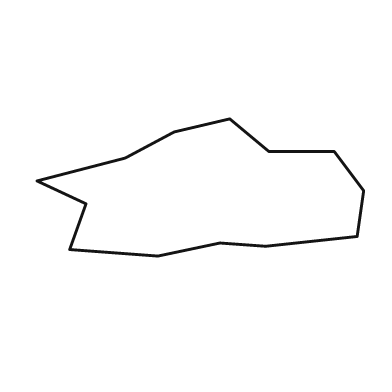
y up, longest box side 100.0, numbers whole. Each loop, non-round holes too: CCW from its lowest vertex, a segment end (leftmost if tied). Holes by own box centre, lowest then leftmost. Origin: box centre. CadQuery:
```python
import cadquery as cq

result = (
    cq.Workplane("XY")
    .moveTo(-13.0, -21.0)
    .lineTo(6.0, -17.0)
    .lineTo(20.0, -18.0)
    .lineTo(48.0, -15.0)
    .lineTo(50.0, -1.0)
    .lineTo(41.0, 11.0)
    .lineTo(21.0, 11.0)
    .lineTo(9.0, 21.0)
    .lineTo(-8.0, 17.0)
    .lineTo(-23.0, 9.0)
    .lineTo(-50.0, 2.0)
    .lineTo(-35.0, -5.0)
    .lineTo(-40.0, -19.0)
    .close()
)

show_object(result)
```